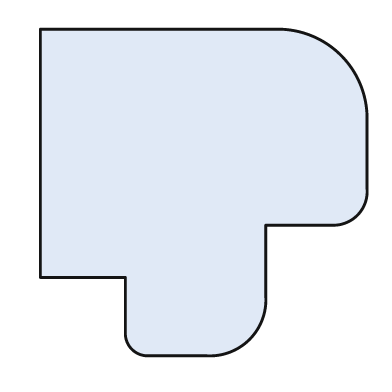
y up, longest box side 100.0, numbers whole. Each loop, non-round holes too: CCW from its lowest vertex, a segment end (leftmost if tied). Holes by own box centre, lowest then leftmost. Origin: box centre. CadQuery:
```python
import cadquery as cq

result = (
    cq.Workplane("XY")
    .moveTo(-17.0, -50.0)
    .lineTo(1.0, -50.0)
    .threePointArc((14.0, -45.0), (19.0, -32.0))
    .lineTo(19.0, -10.0)
    .lineTo(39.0, -10.0)
    .threePointArc((47.0, -7.0), (50.0, 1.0))
    .lineTo(50.0, 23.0)
    .threePointArc((42.0, 42.0), (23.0, 50.0))
    .lineTo(-50.0, 50.0)
    .lineTo(-50.0, -26.0)
    .lineTo(-24.0, -26.0)
    .lineTo(-24.0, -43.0)
    .threePointArc((-22.0, -48.0), (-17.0, -50.0))
    .close()
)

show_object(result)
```